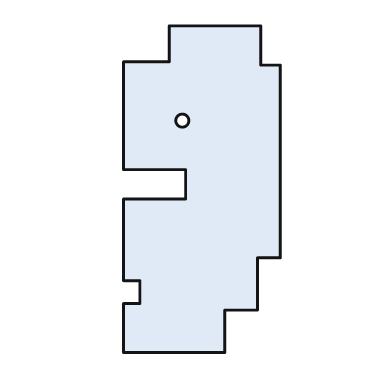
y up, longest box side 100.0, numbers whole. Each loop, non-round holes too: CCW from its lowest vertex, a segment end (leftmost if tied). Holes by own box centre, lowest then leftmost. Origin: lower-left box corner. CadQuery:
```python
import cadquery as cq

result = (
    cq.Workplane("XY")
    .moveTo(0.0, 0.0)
    .lineTo(31.0, 0.0)
    .lineTo(31.0, 13.0)
    .lineTo(41.0, 13.0)
    .lineTo(41.0, 29.0)
    .lineTo(48.0, 29.0)
    .lineTo(48.0, 88.0)
    .lineTo(42.0, 88.0)
    .lineTo(42.0, 100.0)
    .lineTo(14.0, 100.0)
    .lineTo(14.0, 89.0)
    .lineTo(0.0, 89.0)
    .lineTo(0.0, 56.0)
    .lineTo(19.0, 56.0)
    .lineTo(19.0, 47.0)
    .lineTo(0.0, 47.0)
    .lineTo(0.0, 22.0)
    .lineTo(5.0, 22.0)
    .lineTo(5.0, 15.0)
    .lineTo(0.0, 15.0)
    .close()
    .moveTo(18.0, 71.0)
    .circle(2.0)
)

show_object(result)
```